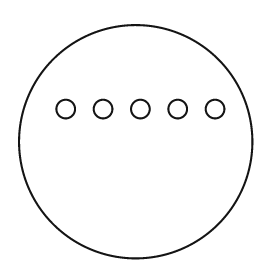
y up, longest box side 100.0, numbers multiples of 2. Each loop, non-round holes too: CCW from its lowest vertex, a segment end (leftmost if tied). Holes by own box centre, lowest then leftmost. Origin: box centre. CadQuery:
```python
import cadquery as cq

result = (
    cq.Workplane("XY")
    .moveTo(0.0, 0.0)
    .circle(50.0)
    .moveTo(-30.0, 14.0)
    .circle(4.0)
    .moveTo(-14.0, 14.0)
    .circle(4.0)
    .moveTo(2.0, 14.0)
    .circle(4.0)
    .moveTo(18.0, 14.0)
    .circle(4.0)
    .moveTo(34.0, 14.0)
    .circle(4.0)
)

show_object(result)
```